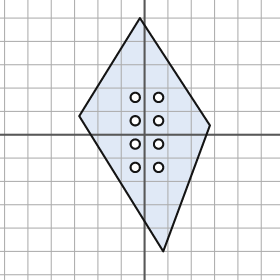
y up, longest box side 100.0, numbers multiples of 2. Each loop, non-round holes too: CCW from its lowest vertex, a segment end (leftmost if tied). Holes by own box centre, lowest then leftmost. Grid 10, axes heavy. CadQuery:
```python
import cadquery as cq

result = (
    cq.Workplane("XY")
    .moveTo(8.0, -50.0)
    .lineTo(28.0, 4.0)
    .lineTo(-2.0, 50.0)
    .lineTo(-28.0, 8.0)
    .close()
    .moveTo(-4.0, -14.0)
    .circle(2.0)
    .moveTo(6.0, -14.0)
    .circle(2.0)
    .moveTo(-4.0, -4.0)
    .circle(2.0)
    .moveTo(6.0, -4.0)
    .circle(2.0)
    .moveTo(-4.0, 6.0)
    .circle(2.0)
    .moveTo(6.0, 6.0)
    .circle(2.0)
    .moveTo(-4.0, 16.0)
    .circle(2.0)
    .moveTo(6.0, 16.0)
    .circle(2.0)
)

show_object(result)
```